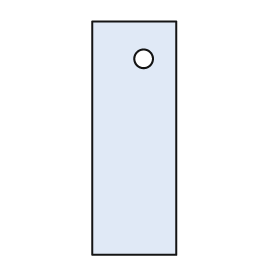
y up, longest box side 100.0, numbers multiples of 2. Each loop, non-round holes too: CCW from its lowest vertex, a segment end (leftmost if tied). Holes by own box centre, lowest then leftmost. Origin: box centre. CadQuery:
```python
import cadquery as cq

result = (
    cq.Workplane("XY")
    .moveTo(-18.0, -50.0)
    .lineTo(18.0, -50.0)
    .lineTo(18.0, 50.0)
    .lineTo(-18.0, 50.0)
    .close()
    .moveTo(4.0, 34.0)
    .circle(4.0)
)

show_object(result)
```